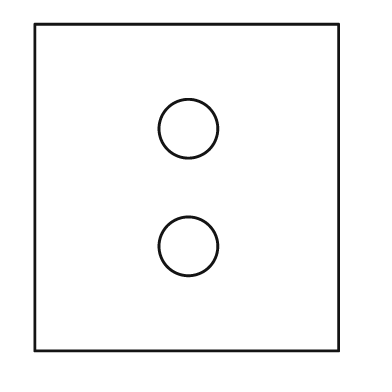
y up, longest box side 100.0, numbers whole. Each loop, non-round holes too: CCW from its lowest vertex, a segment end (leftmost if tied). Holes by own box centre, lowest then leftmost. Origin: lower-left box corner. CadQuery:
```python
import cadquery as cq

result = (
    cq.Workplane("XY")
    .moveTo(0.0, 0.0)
    .lineTo(93.0, 0.0)
    .lineTo(93.0, 100.0)
    .lineTo(0.0, 100.0)
    .close()
    .moveTo(47.0, 32.0)
    .circle(9.0)
    .moveTo(47.0, 68.0)
    .circle(9.0)
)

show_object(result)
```